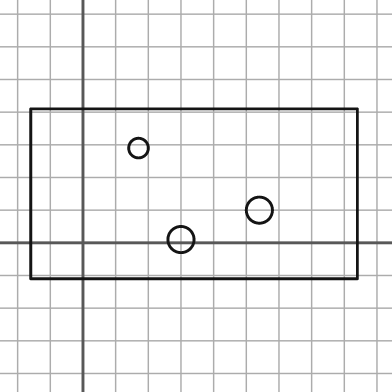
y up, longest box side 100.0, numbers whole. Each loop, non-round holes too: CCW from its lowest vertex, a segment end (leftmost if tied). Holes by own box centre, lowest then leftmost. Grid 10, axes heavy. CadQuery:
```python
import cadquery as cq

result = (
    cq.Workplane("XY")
    .moveTo(-16.0, -11.0)
    .lineTo(84.0, -11.0)
    .lineTo(84.0, 41.0)
    .lineTo(-16.0, 41.0)
    .close()
    .moveTo(30.0, 1.0)
    .circle(4.0)
    .moveTo(54.0, 10.0)
    .circle(4.0)
    .moveTo(17.0, 29.0)
    .circle(3.0)
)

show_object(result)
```